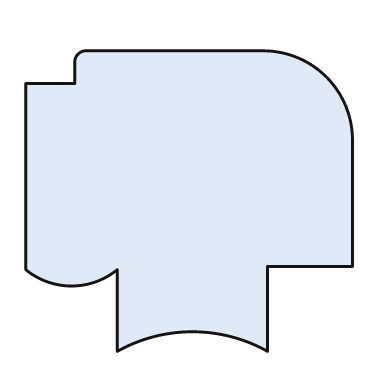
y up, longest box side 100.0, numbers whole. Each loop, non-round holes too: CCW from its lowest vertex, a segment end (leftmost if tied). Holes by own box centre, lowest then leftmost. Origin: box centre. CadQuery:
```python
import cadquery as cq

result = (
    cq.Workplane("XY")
    .moveTo(-22.0, -46.0)
    .threePointArc((1.0, -40.0), (24.0, -46.0))
    .lineTo(24.0, -20.0)
    .lineTo(50.0, -20.0)
    .lineTo(50.0, 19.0)
    .threePointArc((42.0, 38.0), (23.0, 46.0))
    .lineTo(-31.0, 46.0)
    .threePointArc((-34.0, 45.0), (-35.0, 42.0))
    .lineTo(-35.0, 36.0)
    .lineTo(-50.0, 36.0)
    .lineTo(-50.0, -21.0)
    .threePointArc((-36.0, -26.0), (-22.0, -21.0))
    .close()
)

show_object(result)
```